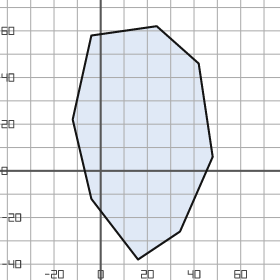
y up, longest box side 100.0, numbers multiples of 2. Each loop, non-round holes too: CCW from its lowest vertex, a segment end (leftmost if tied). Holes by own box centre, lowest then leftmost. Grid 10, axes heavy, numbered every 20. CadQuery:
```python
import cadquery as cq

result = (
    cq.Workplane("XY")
    .moveTo(16.0, -38.0)
    .lineTo(34.0, -26.0)
    .lineTo(48.0, 6.0)
    .lineTo(42.0, 46.0)
    .lineTo(24.0, 62.0)
    .lineTo(-4.0, 58.0)
    .lineTo(-12.0, 22.0)
    .lineTo(-4.0, -12.0)
    .close()
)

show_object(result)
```